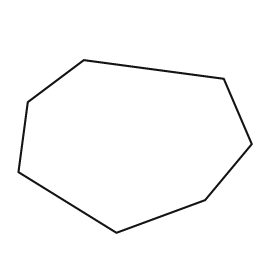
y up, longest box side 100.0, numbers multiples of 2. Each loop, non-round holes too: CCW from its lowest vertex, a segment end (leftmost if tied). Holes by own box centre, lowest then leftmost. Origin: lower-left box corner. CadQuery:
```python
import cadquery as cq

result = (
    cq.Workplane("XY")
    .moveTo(42.0, 0.0)
    .lineTo(80.0, 14.0)
    .lineTo(100.0, 38.0)
    .lineTo(88.0, 66.0)
    .lineTo(28.0, 74.0)
    .lineTo(4.0, 56.0)
    .lineTo(0.0, 26.0)
    .close()
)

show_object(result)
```